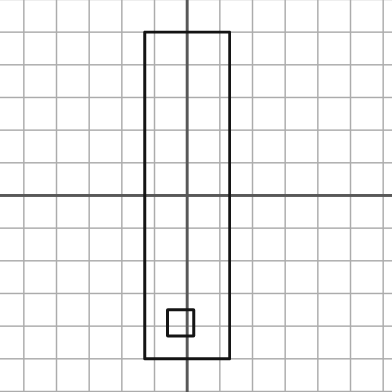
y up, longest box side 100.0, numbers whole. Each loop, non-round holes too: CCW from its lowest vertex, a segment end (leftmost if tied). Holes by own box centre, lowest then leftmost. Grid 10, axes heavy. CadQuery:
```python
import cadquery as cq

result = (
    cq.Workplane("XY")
    .moveTo(-13.0, -50.0)
    .lineTo(13.0, -50.0)
    .lineTo(13.0, 50.0)
    .lineTo(-13.0, 50.0)
    .close()
    .moveTo(-6.0, -43.0)
    .lineTo(2.0, -43.0)
    .lineTo(2.0, -35.0)
    .lineTo(-6.0, -35.0)
    .close()
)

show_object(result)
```